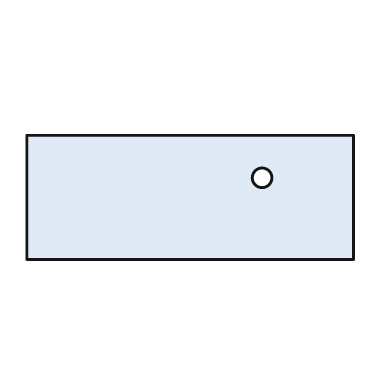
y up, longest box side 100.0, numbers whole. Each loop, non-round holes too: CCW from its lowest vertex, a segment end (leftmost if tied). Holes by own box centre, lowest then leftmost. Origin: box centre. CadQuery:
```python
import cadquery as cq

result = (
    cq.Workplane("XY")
    .moveTo(-50.0, -19.0)
    .lineTo(50.0, -19.0)
    .lineTo(50.0, 19.0)
    .lineTo(-50.0, 19.0)
    .close()
    .moveTo(22.0, 6.0)
    .circle(3.0)
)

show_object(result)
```